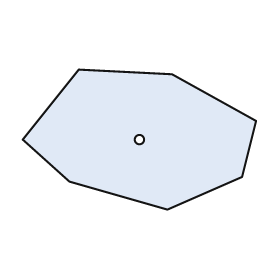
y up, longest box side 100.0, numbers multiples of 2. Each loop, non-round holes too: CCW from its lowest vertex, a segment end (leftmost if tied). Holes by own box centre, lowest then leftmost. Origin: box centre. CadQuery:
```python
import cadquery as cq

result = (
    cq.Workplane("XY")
    .moveTo(12.0, -30.0)
    .lineTo(44.0, -16.0)
    .lineTo(50.0, 8.0)
    .lineTo(14.0, 28.0)
    .lineTo(-26.0, 30.0)
    .lineTo(-50.0, 0.0)
    .lineTo(-30.0, -18.0)
    .close()
    .moveTo(0.0, 0.0)
    .circle(2.0)
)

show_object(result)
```